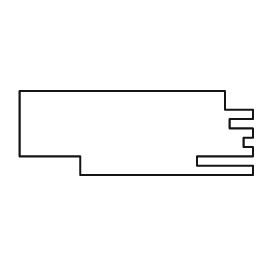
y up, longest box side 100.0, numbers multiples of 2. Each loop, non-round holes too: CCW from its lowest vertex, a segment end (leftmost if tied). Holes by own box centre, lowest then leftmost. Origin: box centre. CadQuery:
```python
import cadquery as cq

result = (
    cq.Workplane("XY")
    .moveTo(-24.0, -18.0)
    .lineTo(50.0, -18.0)
    .lineTo(50.0, -14.0)
    .lineTo(26.0, -14.0)
    .lineTo(26.0, -10.0)
    .lineTo(50.0, -10.0)
    .lineTo(50.0, -6.0)
    .lineTo(46.0, -6.0)
    .lineTo(46.0, -2.0)
    .lineTo(50.0, -2.0)
    .lineTo(50.0, 2.0)
    .lineTo(40.0, 2.0)
    .lineTo(40.0, 6.0)
    .lineTo(50.0, 6.0)
    .lineTo(50.0, 10.0)
    .lineTo(38.0, 10.0)
    .lineTo(38.0, 18.0)
    .lineTo(-50.0, 18.0)
    .lineTo(-50.0, -10.0)
    .lineTo(-24.0, -10.0)
    .close()
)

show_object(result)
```